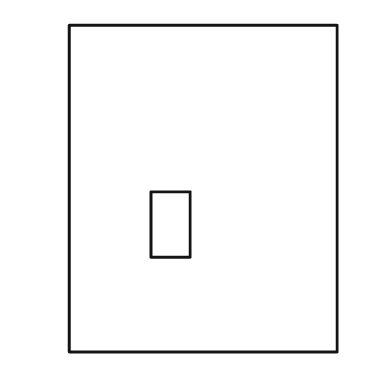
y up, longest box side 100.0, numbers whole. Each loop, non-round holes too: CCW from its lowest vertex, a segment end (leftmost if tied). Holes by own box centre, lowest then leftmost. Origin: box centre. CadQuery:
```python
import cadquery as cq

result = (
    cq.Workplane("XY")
    .moveTo(-41.0, -50.0)
    .lineTo(41.0, -50.0)
    .lineTo(41.0, 50.0)
    .lineTo(-41.0, 50.0)
    .close()
    .moveTo(-16.0, -21.0)
    .lineTo(-4.0, -21.0)
    .lineTo(-4.0, -1.0)
    .lineTo(-16.0, -1.0)
    .close()
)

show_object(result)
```